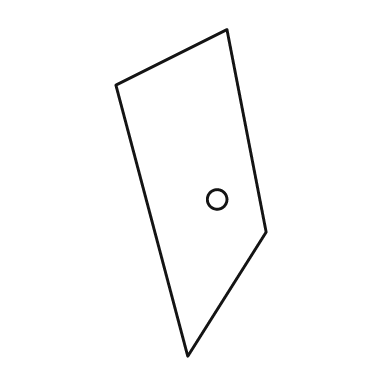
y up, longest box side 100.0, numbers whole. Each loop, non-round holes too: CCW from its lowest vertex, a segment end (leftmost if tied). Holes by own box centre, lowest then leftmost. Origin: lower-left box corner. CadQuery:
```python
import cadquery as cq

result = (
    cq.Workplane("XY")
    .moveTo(22.0, 0.0)
    .lineTo(46.0, 38.0)
    .lineTo(34.0, 100.0)
    .lineTo(0.0, 83.0)
    .close()
    .moveTo(31.0, 48.0)
    .circle(3.0)
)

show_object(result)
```